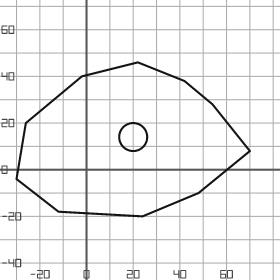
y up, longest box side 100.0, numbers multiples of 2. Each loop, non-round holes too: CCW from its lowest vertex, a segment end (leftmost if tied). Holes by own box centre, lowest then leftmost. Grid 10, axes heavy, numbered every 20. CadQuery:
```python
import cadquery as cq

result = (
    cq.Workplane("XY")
    .moveTo(24.0, -20.0)
    .lineTo(48.0, -10.0)
    .lineTo(70.0, 8.0)
    .lineTo(54.0, 28.0)
    .lineTo(42.0, 38.0)
    .lineTo(22.0, 46.0)
    .lineTo(-2.0, 40.0)
    .lineTo(-26.0, 20.0)
    .lineTo(-30.0, -4.0)
    .lineTo(-12.0, -18.0)
    .close()
    .moveTo(20.0, 14.0)
    .circle(6.0)
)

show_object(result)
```